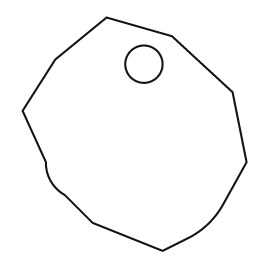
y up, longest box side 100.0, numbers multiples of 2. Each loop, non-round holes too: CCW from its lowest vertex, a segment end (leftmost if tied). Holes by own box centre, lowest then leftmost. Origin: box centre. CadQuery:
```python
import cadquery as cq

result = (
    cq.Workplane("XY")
    .moveTo(12.0, -50.0)
    .lineTo(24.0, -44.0)
    .threePointArc((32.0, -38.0), (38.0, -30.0))
    .lineTo(48.0, -12.0)
    .lineTo(42.0, 18.0)
    .lineTo(16.0, 42.0)
    .lineTo(-12.0, 50.0)
    .lineTo(-34.0, 32.0)
    .lineTo(-48.0, 10.0)
    .lineTo(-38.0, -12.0)
    .threePointArc((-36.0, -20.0), (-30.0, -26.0))
    .lineTo(-18.0, -38.0)
    .close()
    .moveTo(4.0, 30.0)
    .circle(8.0)
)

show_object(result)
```